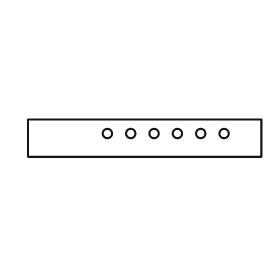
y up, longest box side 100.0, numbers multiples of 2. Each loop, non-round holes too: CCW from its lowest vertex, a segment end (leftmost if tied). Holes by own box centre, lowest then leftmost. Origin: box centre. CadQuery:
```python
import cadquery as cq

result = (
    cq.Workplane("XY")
    .moveTo(-50.0, -8.0)
    .lineTo(50.0, -8.0)
    .lineTo(50.0, 8.0)
    .lineTo(-50.0, 8.0)
    .close()
    .moveTo(-16.0, 2.0)
    .circle(2.0)
    .moveTo(-6.0, 2.0)
    .circle(2.0)
    .moveTo(4.0, 2.0)
    .circle(2.0)
    .moveTo(14.0, 2.0)
    .circle(2.0)
    .moveTo(24.0, 2.0)
    .circle(2.0)
    .moveTo(34.0, 2.0)
    .circle(2.0)
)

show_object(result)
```